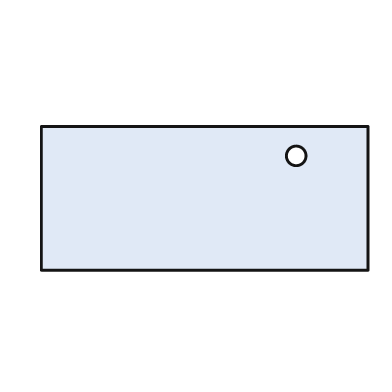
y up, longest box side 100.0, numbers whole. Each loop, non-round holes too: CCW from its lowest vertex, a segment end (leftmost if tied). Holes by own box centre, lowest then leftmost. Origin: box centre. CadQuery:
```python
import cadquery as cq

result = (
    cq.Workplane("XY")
    .moveTo(-50.0, -22.0)
    .lineTo(50.0, -22.0)
    .lineTo(50.0, 22.0)
    .lineTo(-50.0, 22.0)
    .close()
    .moveTo(28.0, 13.0)
    .circle(3.0)
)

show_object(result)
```